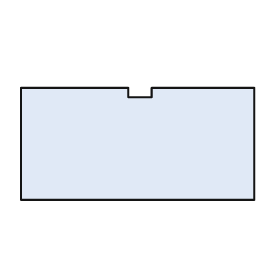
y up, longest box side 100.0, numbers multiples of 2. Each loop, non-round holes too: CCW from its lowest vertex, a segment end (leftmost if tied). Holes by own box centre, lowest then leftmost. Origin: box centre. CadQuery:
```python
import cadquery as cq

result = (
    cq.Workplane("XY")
    .moveTo(-50.0, -24.0)
    .lineTo(50.0, -24.0)
    .lineTo(50.0, 24.0)
    .lineTo(6.0, 24.0)
    .lineTo(6.0, 20.0)
    .lineTo(-4.0, 20.0)
    .lineTo(-4.0, 24.0)
    .lineTo(-50.0, 24.0)
    .close()
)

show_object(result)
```